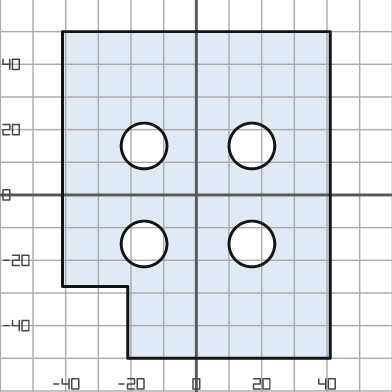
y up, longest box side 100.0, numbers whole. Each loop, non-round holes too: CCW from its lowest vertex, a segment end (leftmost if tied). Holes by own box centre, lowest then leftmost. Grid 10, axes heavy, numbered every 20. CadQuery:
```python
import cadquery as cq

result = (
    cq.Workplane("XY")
    .moveTo(-21.0, -50.0)
    .lineTo(41.0, -50.0)
    .lineTo(41.0, 50.0)
    .lineTo(-41.0, 50.0)
    .lineTo(-41.0, -28.0)
    .lineTo(-21.0, -28.0)
    .close()
    .moveTo(-16.0, -15.0)
    .circle(7.0)
    .moveTo(17.0, -15.0)
    .circle(7.0)
    .moveTo(-16.0, 15.0)
    .circle(7.0)
    .moveTo(17.0, 15.0)
    .circle(7.0)
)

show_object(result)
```